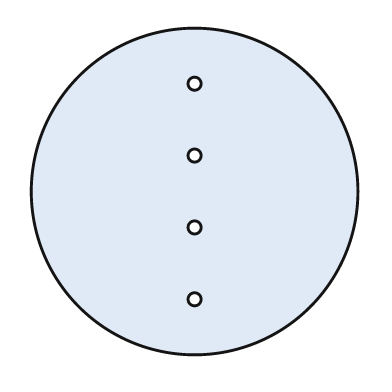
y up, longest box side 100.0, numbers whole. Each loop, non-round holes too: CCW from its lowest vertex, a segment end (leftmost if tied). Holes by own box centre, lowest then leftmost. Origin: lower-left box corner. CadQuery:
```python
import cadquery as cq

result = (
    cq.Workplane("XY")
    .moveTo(50.0, 50.0)
    .circle(50.0)
    .moveTo(50.0, 17.0)
    .circle(2.0)
    .moveTo(50.0, 39.0)
    .circle(2.0)
    .moveTo(50.0, 61.0)
    .circle(2.0)
    .moveTo(50.0, 83.0)
    .circle(2.0)
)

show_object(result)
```